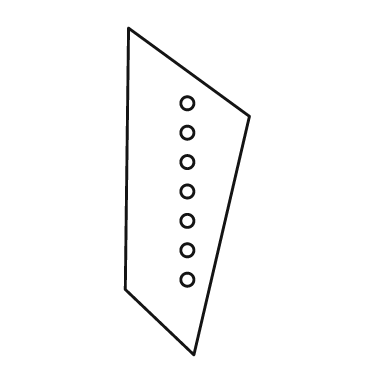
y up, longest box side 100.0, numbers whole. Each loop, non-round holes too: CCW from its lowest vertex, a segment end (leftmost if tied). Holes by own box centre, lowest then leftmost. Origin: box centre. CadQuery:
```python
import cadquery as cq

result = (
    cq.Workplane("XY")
    .moveTo(2.0, -50.0)
    .lineTo(19.0, 23.0)
    .lineTo(-18.0, 50.0)
    .lineTo(-19.0, -30.0)
    .close()
    .moveTo(0.0, -27.0)
    .circle(2.0)
    .moveTo(0.0, -18.0)
    .circle(2.0)
    .moveTo(0.0, -9.0)
    .circle(2.0)
    .moveTo(0.0, 0.0)
    .circle(2.0)
    .moveTo(0.0, 9.0)
    .circle(2.0)
    .moveTo(0.0, 18.0)
    .circle(2.0)
    .moveTo(0.0, 27.0)
    .circle(2.0)
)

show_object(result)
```